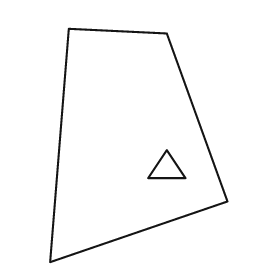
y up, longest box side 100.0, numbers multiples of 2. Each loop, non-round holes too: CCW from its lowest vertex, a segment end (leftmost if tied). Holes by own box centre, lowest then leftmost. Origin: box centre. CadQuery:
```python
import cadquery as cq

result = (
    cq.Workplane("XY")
    .moveTo(-38.0, -50.0)
    .lineTo(38.0, -24.0)
    .lineTo(12.0, 48.0)
    .lineTo(-30.0, 50.0)
    .close()
    .moveTo(4.0, -14.0)
    .lineTo(20.0, -14.0)
    .lineTo(12.0, -2.0)
    .close()
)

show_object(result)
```